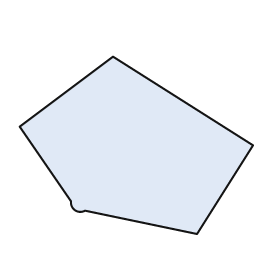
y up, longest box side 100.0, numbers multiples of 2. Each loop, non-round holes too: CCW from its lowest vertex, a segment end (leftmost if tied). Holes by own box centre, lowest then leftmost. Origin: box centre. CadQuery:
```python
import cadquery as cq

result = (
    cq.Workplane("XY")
    .moveTo(26.0, -38.0)
    .lineTo(50.0, 0.0)
    .lineTo(-10.0, 38.0)
    .lineTo(-50.0, 8.0)
    .lineTo(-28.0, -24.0)
    .threePointArc((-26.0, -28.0), (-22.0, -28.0))
    .close()
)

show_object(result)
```